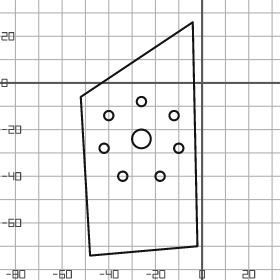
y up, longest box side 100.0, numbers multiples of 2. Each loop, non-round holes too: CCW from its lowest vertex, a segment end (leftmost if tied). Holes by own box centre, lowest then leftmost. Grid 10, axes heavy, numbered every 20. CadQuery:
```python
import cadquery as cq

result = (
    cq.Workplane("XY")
    .moveTo(-48.0, -74.0)
    .lineTo(-2.0, -70.0)
    .lineTo(-4.0, 26.0)
    .lineTo(-52.0, -6.0)
    .close()
    .moveTo(-34.0, -40.0)
    .circle(2.0)
    .moveTo(-18.0, -40.0)
    .circle(2.0)
    .moveTo(-42.0, -28.0)
    .circle(2.0)
    .moveTo(-10.0, -28.0)
    .circle(2.0)
    .moveTo(-26.0, -24.0)
    .circle(4.0)
    .moveTo(-40.0, -14.0)
    .circle(2.0)
    .moveTo(-12.0, -14.0)
    .circle(2.0)
    .moveTo(-26.0, -8.0)
    .circle(2.0)
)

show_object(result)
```